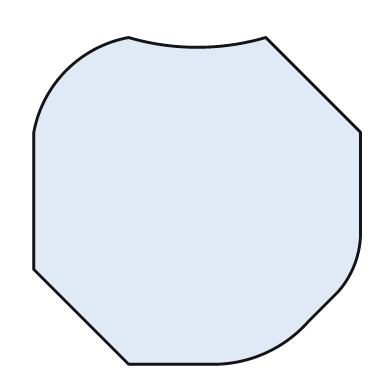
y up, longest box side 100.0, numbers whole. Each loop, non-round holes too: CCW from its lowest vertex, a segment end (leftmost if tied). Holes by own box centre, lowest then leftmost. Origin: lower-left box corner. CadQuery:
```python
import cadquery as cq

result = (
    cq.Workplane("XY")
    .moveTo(29.0, 0.0)
    .lineTo(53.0, 0.0)
    .threePointArc((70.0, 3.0), (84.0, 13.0))
    .lineTo(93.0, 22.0)
    .threePointArc((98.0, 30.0), (100.0, 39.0))
    .lineTo(100.0, 71.0)
    .lineTo(71.0, 100.0)
    .threePointArc((50.0, 97.0), (29.0, 100.0))
    .threePointArc((10.0, 90.0), (0.0, 71.0))
    .lineTo(0.0, 29.0)
    .close()
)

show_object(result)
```